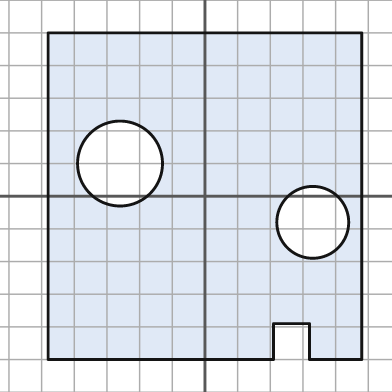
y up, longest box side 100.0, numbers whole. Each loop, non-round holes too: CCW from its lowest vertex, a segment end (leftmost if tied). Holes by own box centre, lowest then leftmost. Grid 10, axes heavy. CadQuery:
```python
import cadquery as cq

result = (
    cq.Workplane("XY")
    .moveTo(-48.0, -50.0)
    .lineTo(21.0, -50.0)
    .lineTo(21.0, -39.0)
    .lineTo(32.0, -39.0)
    .lineTo(32.0, -50.0)
    .lineTo(48.0, -50.0)
    .lineTo(48.0, 50.0)
    .lineTo(-48.0, 50.0)
    .close()
    .moveTo(33.0, -8.0)
    .circle(11.0)
    .moveTo(-26.0, 10.0)
    .circle(13.0)
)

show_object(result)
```